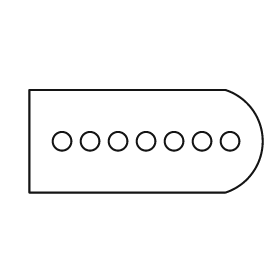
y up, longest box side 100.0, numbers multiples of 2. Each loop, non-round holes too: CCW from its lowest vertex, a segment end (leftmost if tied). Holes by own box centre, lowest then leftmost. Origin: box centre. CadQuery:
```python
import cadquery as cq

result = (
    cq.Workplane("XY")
    .moveTo(-50.0, -22.0)
    .lineTo(34.0, -22.0)
    .threePointArc((50.0, 0.0), (34.0, 22.0))
    .lineTo(-50.0, 22.0)
    .close()
    .moveTo(-36.0, 0.0)
    .circle(4.0)
    .moveTo(-24.0, 0.0)
    .circle(4.0)
    .moveTo(-12.0, 0.0)
    .circle(4.0)
    .moveTo(0.0, 0.0)
    .circle(4.0)
    .moveTo(12.0, 0.0)
    .circle(4.0)
    .moveTo(24.0, 0.0)
    .circle(4.0)
    .moveTo(36.0, 0.0)
    .circle(4.0)
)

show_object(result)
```